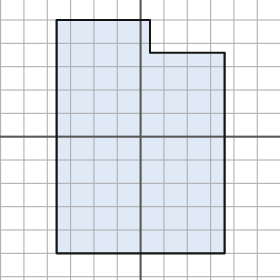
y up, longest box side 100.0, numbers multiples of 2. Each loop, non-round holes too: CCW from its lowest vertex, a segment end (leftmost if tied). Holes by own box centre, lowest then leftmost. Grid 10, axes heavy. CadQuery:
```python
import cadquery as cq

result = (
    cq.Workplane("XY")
    .moveTo(-36.0, -50.0)
    .lineTo(36.0, -50.0)
    .lineTo(36.0, 36.0)
    .lineTo(4.0, 36.0)
    .lineTo(4.0, 50.0)
    .lineTo(-36.0, 50.0)
    .close()
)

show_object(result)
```